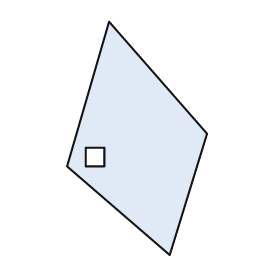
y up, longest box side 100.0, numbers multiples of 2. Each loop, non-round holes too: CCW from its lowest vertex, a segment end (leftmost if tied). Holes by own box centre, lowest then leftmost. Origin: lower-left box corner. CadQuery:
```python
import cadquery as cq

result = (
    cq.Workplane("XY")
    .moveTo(44.0, 0.0)
    .lineTo(60.0, 52.0)
    .lineTo(18.0, 100.0)
    .lineTo(0.0, 38.0)
    .close()
    .moveTo(8.0, 38.0)
    .lineTo(16.0, 38.0)
    .lineTo(16.0, 46.0)
    .lineTo(8.0, 46.0)
    .close()
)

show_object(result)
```